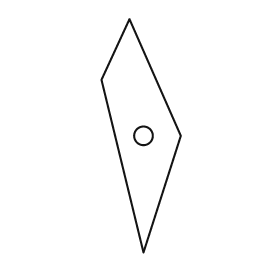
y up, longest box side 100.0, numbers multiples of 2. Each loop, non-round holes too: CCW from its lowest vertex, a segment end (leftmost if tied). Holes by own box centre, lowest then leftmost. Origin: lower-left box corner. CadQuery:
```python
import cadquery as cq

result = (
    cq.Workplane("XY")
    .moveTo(18.0, 0.0)
    .lineTo(34.0, 50.0)
    .lineTo(12.0, 100.0)
    .lineTo(0.0, 74.0)
    .close()
    .moveTo(18.0, 50.0)
    .circle(4.0)
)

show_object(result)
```